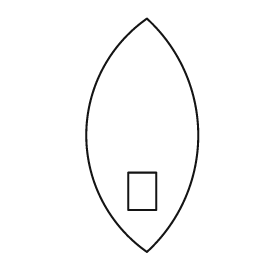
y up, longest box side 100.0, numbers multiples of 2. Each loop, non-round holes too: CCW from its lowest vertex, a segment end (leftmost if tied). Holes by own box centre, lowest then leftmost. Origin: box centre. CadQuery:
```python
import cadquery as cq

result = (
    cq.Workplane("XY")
    .moveTo(2.0, -50.0)
    .threePointArc((24.0, 0.0), (2.0, 50.0))
    .threePointArc((-24.0, 0.0), (2.0, -50.0))
    .close()
    .moveTo(-6.0, -32.0)
    .lineTo(6.0, -32.0)
    .lineTo(6.0, -16.0)
    .lineTo(-6.0, -16.0)
    .close()
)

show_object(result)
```